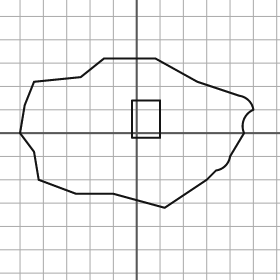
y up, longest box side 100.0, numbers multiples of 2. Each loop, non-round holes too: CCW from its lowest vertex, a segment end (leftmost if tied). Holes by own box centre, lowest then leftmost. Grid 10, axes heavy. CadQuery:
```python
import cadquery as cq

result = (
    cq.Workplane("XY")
    .moveTo(12.0, -32.0)
    .lineTo(30.0, -20.0)
    .lineTo(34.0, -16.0)
    .threePointArc((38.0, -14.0), (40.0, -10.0))
    .lineTo(46.0, 0.0)
    .threePointArc((46.0, 6.0), (50.0, 10.0))
    .threePointArc((48.0, 14.0), (44.0, 16.0))
    .lineTo(26.0, 22.0)
    .lineTo(8.0, 32.0)
    .lineTo(-14.0, 32.0)
    .lineTo(-24.0, 24.0)
    .lineTo(-44.0, 22.0)
    .lineTo(-48.0, 12.0)
    .lineTo(-50.0, 0.0)
    .lineTo(-44.0, -8.0)
    .lineTo(-42.0, -20.0)
    .lineTo(-26.0, -26.0)
    .lineTo(-10.0, -26.0)
    .close()
    .moveTo(-2.0, -2.0)
    .lineTo(10.0, -2.0)
    .lineTo(10.0, 14.0)
    .lineTo(-2.0, 14.0)
    .close()
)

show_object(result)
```